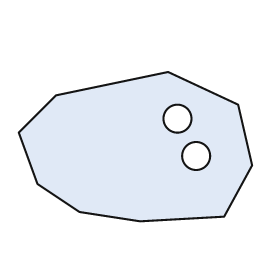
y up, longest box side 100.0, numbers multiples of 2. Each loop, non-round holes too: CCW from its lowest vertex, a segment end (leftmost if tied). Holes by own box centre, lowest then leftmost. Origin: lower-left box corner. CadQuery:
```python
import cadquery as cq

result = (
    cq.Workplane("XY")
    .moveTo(52.0, 0.0)
    .lineTo(88.0, 2.0)
    .lineTo(100.0, 24.0)
    .lineTo(94.0, 50.0)
    .lineTo(64.0, 64.0)
    .lineTo(16.0, 54.0)
    .lineTo(0.0, 38.0)
    .lineTo(8.0, 16.0)
    .lineTo(26.0, 4.0)
    .close()
    .moveTo(76.0, 28.0)
    .circle(6.0)
    .moveTo(68.0, 44.0)
    .circle(6.0)
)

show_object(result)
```